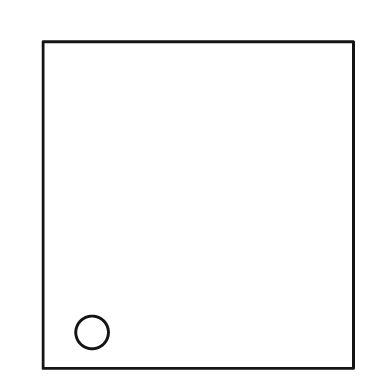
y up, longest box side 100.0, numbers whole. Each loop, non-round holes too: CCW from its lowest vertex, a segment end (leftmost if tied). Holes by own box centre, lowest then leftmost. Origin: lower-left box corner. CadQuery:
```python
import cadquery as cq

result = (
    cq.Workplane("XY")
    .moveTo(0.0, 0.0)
    .lineTo(95.0, 0.0)
    .lineTo(95.0, 100.0)
    .lineTo(0.0, 100.0)
    .close()
    .moveTo(15.0, 11.0)
    .circle(5.0)
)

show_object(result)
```